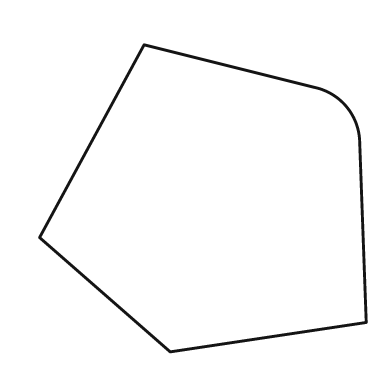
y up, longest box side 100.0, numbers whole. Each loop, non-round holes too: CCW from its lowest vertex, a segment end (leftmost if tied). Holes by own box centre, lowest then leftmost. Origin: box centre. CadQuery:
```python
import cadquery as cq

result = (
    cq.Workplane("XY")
    .moveTo(-10.0, -47.0)
    .lineTo(50.0, -38.0)
    .lineTo(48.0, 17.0)
    .threePointArc((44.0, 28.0), (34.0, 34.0))
    .lineTo(-18.0, 47.0)
    .lineTo(-50.0, -12.0)
    .close()
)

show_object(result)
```